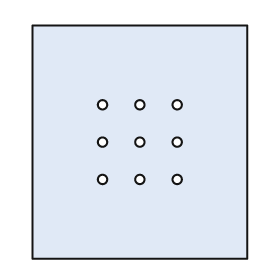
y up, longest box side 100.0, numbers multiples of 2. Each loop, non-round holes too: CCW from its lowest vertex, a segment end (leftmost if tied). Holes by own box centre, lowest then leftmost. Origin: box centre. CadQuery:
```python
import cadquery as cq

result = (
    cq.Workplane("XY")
    .moveTo(-46.0, -50.0)
    .lineTo(46.0, -50.0)
    .lineTo(46.0, 50.0)
    .lineTo(-46.0, 50.0)
    .close()
    .moveTo(-16.0, -16.0)
    .circle(2.0)
    .moveTo(0.0, -16.0)
    .circle(2.0)
    .moveTo(16.0, -16.0)
    .circle(2.0)
    .moveTo(-16.0, 0.0)
    .circle(2.0)
    .moveTo(0.0, 0.0)
    .circle(2.0)
    .moveTo(16.0, 0.0)
    .circle(2.0)
    .moveTo(-16.0, 16.0)
    .circle(2.0)
    .moveTo(0.0, 16.0)
    .circle(2.0)
    .moveTo(16.0, 16.0)
    .circle(2.0)
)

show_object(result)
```